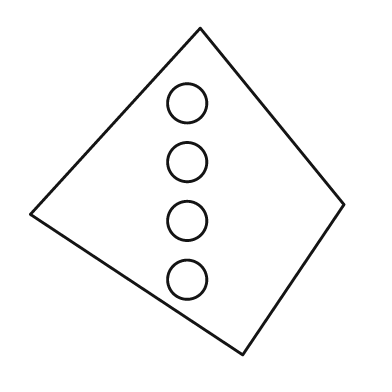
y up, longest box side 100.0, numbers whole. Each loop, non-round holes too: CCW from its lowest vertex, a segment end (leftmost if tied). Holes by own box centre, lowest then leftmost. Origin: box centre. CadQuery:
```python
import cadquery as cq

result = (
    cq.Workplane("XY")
    .moveTo(17.0, -50.0)
    .lineTo(48.0, -4.0)
    .lineTo(4.0, 50.0)
    .lineTo(-48.0, -7.0)
    .close()
    .moveTo(0.0, -27.0)
    .circle(6.0)
    .moveTo(0.0, -9.0)
    .circle(6.0)
    .moveTo(0.0, 9.0)
    .circle(6.0)
    .moveTo(0.0, 27.0)
    .circle(6.0)
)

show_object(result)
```